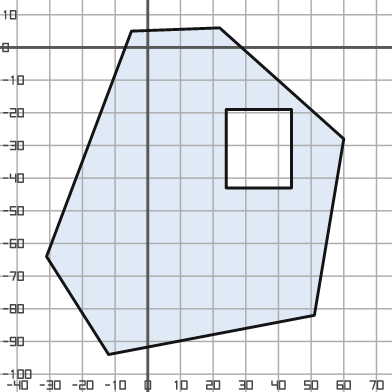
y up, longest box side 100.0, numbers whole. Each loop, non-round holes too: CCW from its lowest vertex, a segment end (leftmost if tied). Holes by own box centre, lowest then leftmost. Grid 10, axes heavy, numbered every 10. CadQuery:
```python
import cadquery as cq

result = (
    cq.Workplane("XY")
    .moveTo(-12.0, -94.0)
    .lineTo(51.0, -82.0)
    .lineTo(60.0, -28.0)
    .lineTo(22.0, 6.0)
    .lineTo(-5.0, 5.0)
    .lineTo(-31.0, -64.0)
    .close()
    .moveTo(24.0, -43.0)
    .lineTo(44.0, -43.0)
    .lineTo(44.0, -19.0)
    .lineTo(24.0, -19.0)
    .close()
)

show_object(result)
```